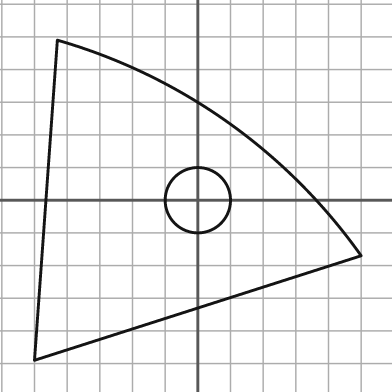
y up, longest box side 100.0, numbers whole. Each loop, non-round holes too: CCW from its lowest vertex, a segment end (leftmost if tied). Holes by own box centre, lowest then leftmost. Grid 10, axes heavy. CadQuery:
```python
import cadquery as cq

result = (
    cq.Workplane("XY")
    .moveTo(-50.0, -49.0)
    .lineTo(50.0, -17.0)
    .threePointArc((9.0, 24.0), (-43.0, 49.0))
    .close()
    .moveTo(0.0, 0.0)
    .circle(10.0)
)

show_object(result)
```